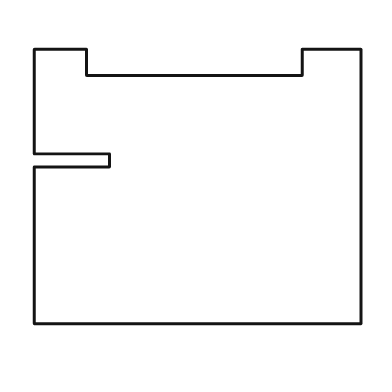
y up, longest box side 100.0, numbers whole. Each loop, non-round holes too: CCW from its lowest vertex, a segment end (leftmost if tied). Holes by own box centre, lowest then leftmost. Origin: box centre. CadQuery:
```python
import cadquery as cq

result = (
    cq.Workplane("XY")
    .moveTo(-50.0, -42.0)
    .lineTo(50.0, -42.0)
    .lineTo(50.0, 42.0)
    .lineTo(32.0, 42.0)
    .lineTo(32.0, 34.0)
    .lineTo(-34.0, 34.0)
    .lineTo(-34.0, 42.0)
    .lineTo(-50.0, 42.0)
    .lineTo(-50.0, 10.0)
    .lineTo(-27.0, 10.0)
    .lineTo(-27.0, 6.0)
    .lineTo(-50.0, 6.0)
    .close()
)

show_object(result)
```